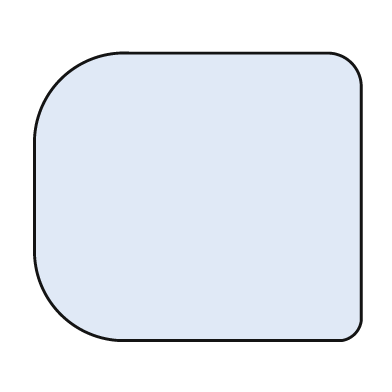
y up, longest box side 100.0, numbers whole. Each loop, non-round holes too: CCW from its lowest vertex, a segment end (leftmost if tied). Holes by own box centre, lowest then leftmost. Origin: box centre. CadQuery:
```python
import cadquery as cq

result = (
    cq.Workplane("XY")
    .moveTo(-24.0, -44.0)
    .lineTo(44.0, -44.0)
    .threePointArc((48.0, -42.0), (50.0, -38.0))
    .lineTo(50.0, 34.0)
    .threePointArc((47.0, 41.0), (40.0, 44.0))
    .lineTo(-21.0, 44.0)
    .threePointArc((-42.0, 36.0), (-50.0, 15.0))
    .lineTo(-50.0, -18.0)
    .threePointArc((-42.0, -36.0), (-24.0, -44.0))
    .close()
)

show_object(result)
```